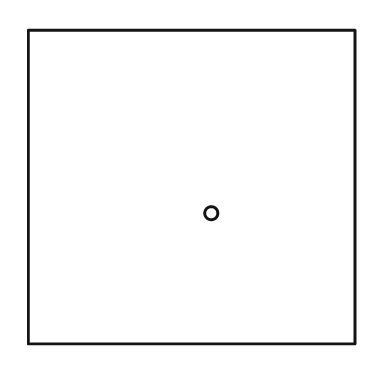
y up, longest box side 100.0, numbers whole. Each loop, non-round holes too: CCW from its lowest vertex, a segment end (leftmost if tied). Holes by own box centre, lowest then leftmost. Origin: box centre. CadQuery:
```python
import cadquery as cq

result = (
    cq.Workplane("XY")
    .moveTo(-50.0, -48.0)
    .lineTo(50.0, -48.0)
    .lineTo(50.0, 48.0)
    .lineTo(-50.0, 48.0)
    .close()
    .moveTo(6.0, -8.0)
    .circle(2.0)
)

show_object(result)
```